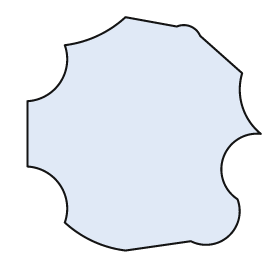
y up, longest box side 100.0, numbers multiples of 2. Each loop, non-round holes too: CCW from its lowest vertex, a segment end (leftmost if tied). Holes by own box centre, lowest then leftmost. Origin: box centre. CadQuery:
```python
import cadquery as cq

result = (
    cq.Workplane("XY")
    .moveTo(-8.0, -50.0)
    .lineTo(20.0, -46.0)
    .threePointArc((36.0, -44.0), (40.0, -28.0))
    .threePointArc((34.0, -10.0), (50.0, 0.0))
    .threePointArc((42.0, 12.0), (42.0, 26.0))
    .lineTo(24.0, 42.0)
    .threePointArc((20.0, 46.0), (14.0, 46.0))
    .lineTo(-8.0, 50.0)
    .threePointArc((-20.0, 42.0), (-34.0, 38.0))
    .threePointArc((-36.0, 22.0), (-50.0, 14.0))
    .lineTo(-50.0, -14.0)
    .threePointArc((-36.0, -22.0), (-34.0, -38.0))
    .threePointArc((-22.0, -46.0), (-8.0, -50.0))
    .close()
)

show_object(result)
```